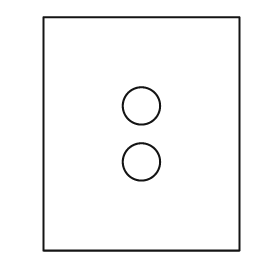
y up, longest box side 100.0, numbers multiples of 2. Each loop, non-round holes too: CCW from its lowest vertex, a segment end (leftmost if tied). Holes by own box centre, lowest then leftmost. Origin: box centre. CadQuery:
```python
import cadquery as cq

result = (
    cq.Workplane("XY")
    .moveTo(-42.0, -50.0)
    .lineTo(42.0, -50.0)
    .lineTo(42.0, 50.0)
    .lineTo(-42.0, 50.0)
    .close()
    .moveTo(0.0, -12.0)
    .circle(8.0)
    .moveTo(0.0, 12.0)
    .circle(8.0)
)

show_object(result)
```